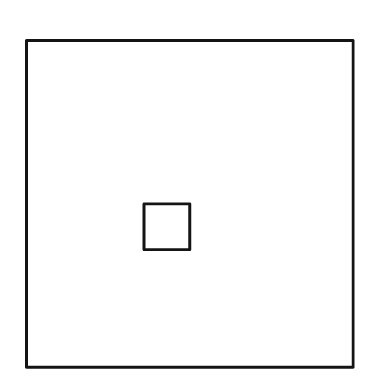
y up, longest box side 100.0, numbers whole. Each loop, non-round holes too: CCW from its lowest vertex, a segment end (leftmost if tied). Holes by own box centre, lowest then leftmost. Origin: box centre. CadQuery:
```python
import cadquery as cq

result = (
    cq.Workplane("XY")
    .moveTo(-50.0, -50.0)
    .lineTo(50.0, -50.0)
    .lineTo(50.0, 50.0)
    .lineTo(-50.0, 50.0)
    .close()
    .moveTo(-14.0, -14.0)
    .lineTo(0.0, -14.0)
    .lineTo(0.0, 0.0)
    .lineTo(-14.0, 0.0)
    .close()
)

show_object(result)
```